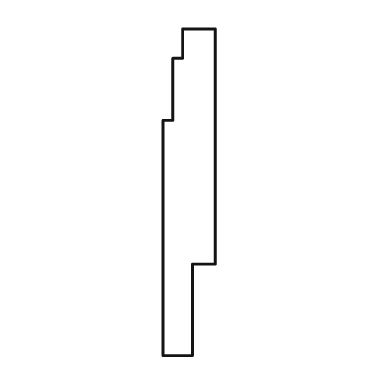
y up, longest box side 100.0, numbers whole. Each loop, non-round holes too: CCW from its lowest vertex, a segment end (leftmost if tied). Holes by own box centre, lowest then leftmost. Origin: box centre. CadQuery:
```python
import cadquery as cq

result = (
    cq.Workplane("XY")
    .moveTo(-8.0, -50.0)
    .lineTo(1.0, -50.0)
    .lineTo(1.0, -22.0)
    .lineTo(8.0, -22.0)
    .lineTo(8.0, 50.0)
    .lineTo(-2.0, 50.0)
    .lineTo(-2.0, 41.0)
    .lineTo(-5.0, 41.0)
    .lineTo(-5.0, 22.0)
    .lineTo(-8.0, 22.0)
    .close()
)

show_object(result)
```